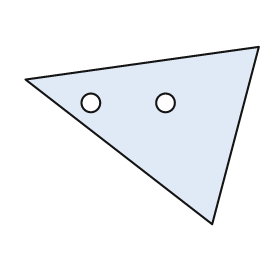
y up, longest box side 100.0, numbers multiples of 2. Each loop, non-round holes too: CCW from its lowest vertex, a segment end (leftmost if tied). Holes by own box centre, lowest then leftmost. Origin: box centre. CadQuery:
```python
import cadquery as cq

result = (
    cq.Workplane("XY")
    .moveTo(30.0, -38.0)
    .lineTo(50.0, 38.0)
    .lineTo(-50.0, 24.0)
    .close()
    .moveTo(-22.0, 14.0)
    .circle(4.0)
    .moveTo(10.0, 14.0)
    .circle(4.0)
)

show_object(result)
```